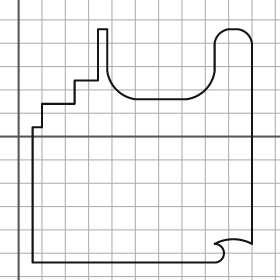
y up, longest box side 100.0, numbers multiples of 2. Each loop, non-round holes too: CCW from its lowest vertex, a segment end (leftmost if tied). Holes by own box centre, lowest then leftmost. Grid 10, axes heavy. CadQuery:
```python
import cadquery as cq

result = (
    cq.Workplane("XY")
    .moveTo(6.0, -54.0)
    .lineTo(84.0, -54.0)
    .threePointArc((88.0, -50.0), (84.0, -46.0))
    .threePointArc((92.0, -44.0), (100.0, -46.0))
    .lineTo(100.0, 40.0)
    .threePointArc((98.0, 44.0), (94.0, 46.0))
    .lineTo(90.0, 46.0)
    .threePointArc((86.0, 44.0), (84.0, 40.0))
    .lineTo(84.0, 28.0)
    .threePointArc((80.0, 20.0), (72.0, 16.0))
    .lineTo(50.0, 16.0)
    .threePointArc((42.0, 20.0), (38.0, 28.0))
    .lineTo(38.0, 46.0)
    .lineTo(34.0, 46.0)
    .lineTo(34.0, 24.0)
    .lineTo(24.0, 24.0)
    .lineTo(24.0, 14.0)
    .lineTo(10.0, 14.0)
    .lineTo(10.0, 4.0)
    .lineTo(6.0, 4.0)
    .close()
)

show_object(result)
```